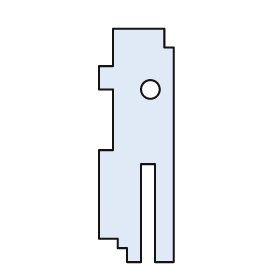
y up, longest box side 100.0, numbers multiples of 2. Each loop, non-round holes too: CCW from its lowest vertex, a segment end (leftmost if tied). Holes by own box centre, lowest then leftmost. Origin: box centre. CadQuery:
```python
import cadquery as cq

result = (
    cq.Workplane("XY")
    .moveTo(-4.0, -50.0)
    .lineTo(2.0, -50.0)
    .lineTo(2.0, -8.0)
    .lineTo(8.0, -8.0)
    .lineTo(8.0, -50.0)
    .lineTo(16.0, -50.0)
    .lineTo(16.0, 42.0)
    .lineTo(12.0, 42.0)
    .lineTo(12.0, 50.0)
    .lineTo(-10.0, 50.0)
    .lineTo(-10.0, 34.0)
    .lineTo(-16.0, 34.0)
    .lineTo(-16.0, 24.0)
    .lineTo(-10.0, 24.0)
    .lineTo(-10.0, -2.0)
    .lineTo(-16.0, -2.0)
    .lineTo(-16.0, -40.0)
    .lineTo(-8.0, -40.0)
    .lineTo(-8.0, -44.0)
    .lineTo(-4.0, -44.0)
    .close()
    .moveTo(6.0, 24.0)
    .circle(4.0)
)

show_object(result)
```